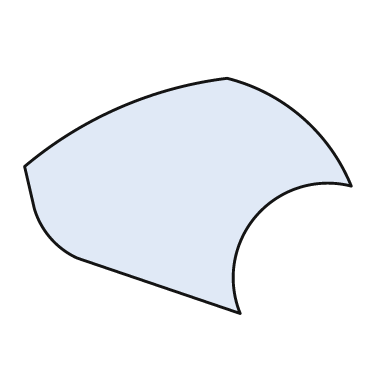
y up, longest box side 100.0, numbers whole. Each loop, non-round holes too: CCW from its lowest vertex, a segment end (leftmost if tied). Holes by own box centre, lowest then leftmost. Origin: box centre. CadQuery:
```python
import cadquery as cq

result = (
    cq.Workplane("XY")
    .moveTo(16.0, -36.0)
    .threePointArc((21.0, -6.0), (50.0, 3.0))
    .threePointArc((35.0, 24.0), (12.0, 36.0))
    .threePointArc((-21.0, 27.0), (-50.0, 9.0))
    .lineTo(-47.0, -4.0)
    .threePointArc((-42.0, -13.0), (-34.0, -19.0))
    .close()
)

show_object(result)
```